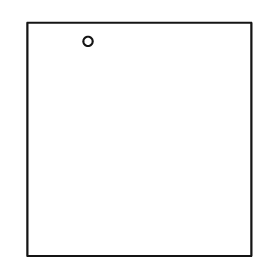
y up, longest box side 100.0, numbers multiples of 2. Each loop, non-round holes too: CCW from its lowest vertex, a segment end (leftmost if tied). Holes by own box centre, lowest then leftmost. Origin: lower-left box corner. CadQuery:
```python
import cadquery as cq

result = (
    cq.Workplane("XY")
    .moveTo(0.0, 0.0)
    .lineTo(96.0, 0.0)
    .lineTo(96.0, 100.0)
    .lineTo(0.0, 100.0)
    .close()
    .moveTo(26.0, 92.0)
    .circle(2.0)
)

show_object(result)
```